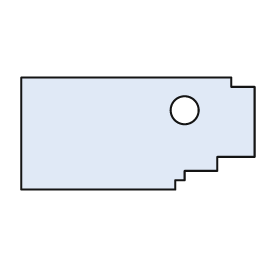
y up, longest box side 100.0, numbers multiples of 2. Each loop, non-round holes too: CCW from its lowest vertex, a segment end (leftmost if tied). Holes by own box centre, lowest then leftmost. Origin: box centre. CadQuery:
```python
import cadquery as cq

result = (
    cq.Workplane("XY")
    .moveTo(-50.0, -24.0)
    .lineTo(16.0, -24.0)
    .lineTo(16.0, -20.0)
    .lineTo(20.0, -20.0)
    .lineTo(20.0, -16.0)
    .lineTo(34.0, -16.0)
    .lineTo(34.0, -10.0)
    .lineTo(50.0, -10.0)
    .lineTo(50.0, 20.0)
    .lineTo(40.0, 20.0)
    .lineTo(40.0, 24.0)
    .lineTo(-50.0, 24.0)
    .close()
    .moveTo(20.0, 10.0)
    .circle(6.0)
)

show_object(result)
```